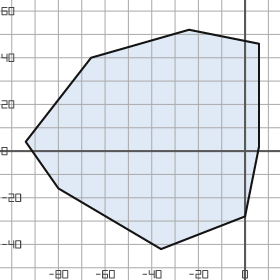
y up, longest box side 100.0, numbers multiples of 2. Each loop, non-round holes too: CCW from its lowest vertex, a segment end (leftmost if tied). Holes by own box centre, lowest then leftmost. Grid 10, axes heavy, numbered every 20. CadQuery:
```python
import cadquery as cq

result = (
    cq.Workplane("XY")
    .moveTo(-36.0, -42.0)
    .lineTo(0.0, -28.0)
    .lineTo(6.0, 2.0)
    .lineTo(6.0, 46.0)
    .lineTo(-24.0, 52.0)
    .lineTo(-66.0, 40.0)
    .lineTo(-94.0, 4.0)
    .lineTo(-80.0, -16.0)
    .close()
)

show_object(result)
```